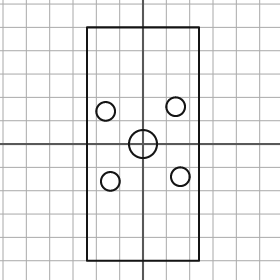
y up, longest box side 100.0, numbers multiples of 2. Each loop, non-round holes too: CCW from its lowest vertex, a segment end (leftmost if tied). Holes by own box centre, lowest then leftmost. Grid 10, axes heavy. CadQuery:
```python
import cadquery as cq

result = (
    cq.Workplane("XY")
    .moveTo(-24.0, -50.0)
    .lineTo(24.0, -50.0)
    .lineTo(24.0, 50.0)
    .lineTo(-24.0, 50.0)
    .close()
    .moveTo(-14.0, -16.0)
    .circle(4.0)
    .moveTo(16.0, -14.0)
    .circle(4.0)
    .moveTo(0.0, 0.0)
    .circle(6.0)
    .moveTo(-16.0, 14.0)
    .circle(4.0)
    .moveTo(14.0, 16.0)
    .circle(4.0)
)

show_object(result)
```